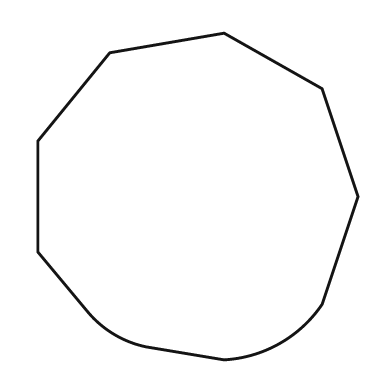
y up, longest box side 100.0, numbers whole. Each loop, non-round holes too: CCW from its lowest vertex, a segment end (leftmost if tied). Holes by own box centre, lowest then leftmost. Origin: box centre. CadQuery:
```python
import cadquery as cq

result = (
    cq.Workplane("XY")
    .moveTo(8.0, -50.0)
    .threePointArc((25.0, -45.0), (38.0, -33.0))
    .lineTo(49.0, 0.0)
    .lineTo(38.0, 33.0)
    .lineTo(8.0, 50.0)
    .lineTo(-27.0, 44.0)
    .lineTo(-49.0, 17.0)
    .lineTo(-49.0, -17.0)
    .lineTo(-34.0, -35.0)
    .threePointArc((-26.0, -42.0), (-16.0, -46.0))
    .close()
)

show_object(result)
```